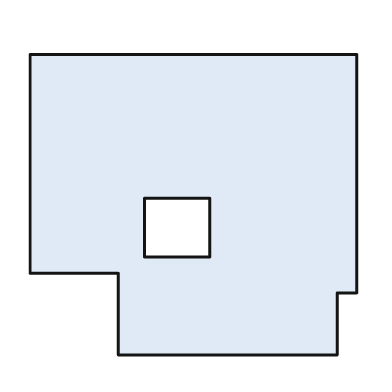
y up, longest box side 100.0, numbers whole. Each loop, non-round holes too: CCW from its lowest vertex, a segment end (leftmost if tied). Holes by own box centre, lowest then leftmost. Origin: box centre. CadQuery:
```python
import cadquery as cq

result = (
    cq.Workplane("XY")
    .moveTo(-23.0, -46.0)
    .lineTo(44.0, -46.0)
    .lineTo(44.0, -27.0)
    .lineTo(50.0, -27.0)
    .lineTo(50.0, 46.0)
    .lineTo(-50.0, 46.0)
    .lineTo(-50.0, -21.0)
    .lineTo(-23.0, -21.0)
    .close()
    .moveTo(-15.0, -16.0)
    .lineTo(5.0, -16.0)
    .lineTo(5.0, 2.0)
    .lineTo(-15.0, 2.0)
    .close()
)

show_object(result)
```